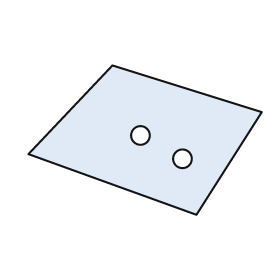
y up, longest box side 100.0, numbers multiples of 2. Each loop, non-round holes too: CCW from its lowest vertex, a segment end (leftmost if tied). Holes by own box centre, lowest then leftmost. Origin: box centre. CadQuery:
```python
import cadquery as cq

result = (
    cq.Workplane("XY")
    .moveTo(22.0, -32.0)
    .lineTo(50.0, 12.0)
    .lineTo(-14.0, 32.0)
    .lineTo(-50.0, -6.0)
    .close()
    .moveTo(16.0, -8.0)
    .circle(4.0)
    .moveTo(-2.0, 2.0)
    .circle(4.0)
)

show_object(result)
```